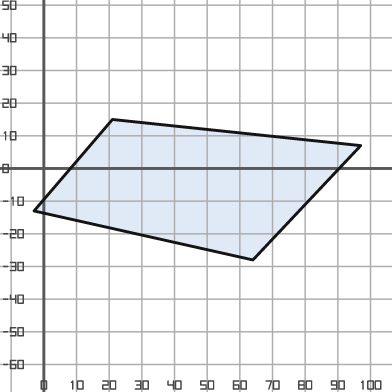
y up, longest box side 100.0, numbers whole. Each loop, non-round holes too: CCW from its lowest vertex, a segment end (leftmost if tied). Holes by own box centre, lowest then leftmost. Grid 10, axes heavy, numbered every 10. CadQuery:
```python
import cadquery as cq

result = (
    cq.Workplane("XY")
    .moveTo(64.0, -28.0)
    .lineTo(97.0, 7.0)
    .lineTo(21.0, 15.0)
    .lineTo(-3.0, -13.0)
    .close()
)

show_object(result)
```